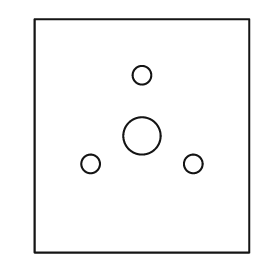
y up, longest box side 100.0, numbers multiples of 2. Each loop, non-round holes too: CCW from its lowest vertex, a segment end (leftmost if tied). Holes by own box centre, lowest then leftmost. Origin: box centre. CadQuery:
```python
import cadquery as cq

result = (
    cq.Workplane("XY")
    .moveTo(-46.0, -50.0)
    .lineTo(46.0, -50.0)
    .lineTo(46.0, 50.0)
    .lineTo(-46.0, 50.0)
    .close()
    .moveTo(-22.0, -12.0)
    .circle(4.0)
    .moveTo(22.0, -12.0)
    .circle(4.0)
    .moveTo(0.0, 0.0)
    .circle(8.0)
    .moveTo(0.0, 26.0)
    .circle(4.0)
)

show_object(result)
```